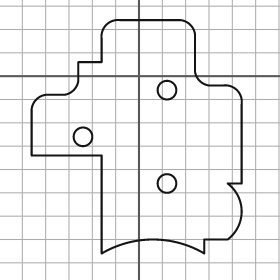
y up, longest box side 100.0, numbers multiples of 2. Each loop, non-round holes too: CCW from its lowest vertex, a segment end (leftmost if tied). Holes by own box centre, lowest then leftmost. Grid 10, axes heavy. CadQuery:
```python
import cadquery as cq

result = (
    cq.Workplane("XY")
    .moveTo(-16.0, -76.0)
    .threePointArc((6.0, -70.0), (28.0, -76.0))
    .lineTo(28.0, -70.0)
    .lineTo(38.0, -70.0)
    .threePointArc((44.0, -58.0), (38.0, -46.0))
    .lineTo(44.0, -46.0)
    .lineTo(44.0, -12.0)
    .threePointArc((42.0, -6.0), (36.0, -4.0))
    .lineTo(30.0, -4.0)
    .threePointArc((26.0, -2.0), (24.0, 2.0))
    .lineTo(24.0, 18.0)
    .threePointArc((22.0, 22.0), (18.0, 24.0))
    .lineTo(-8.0, 24.0)
    .threePointArc((-14.0, 22.0), (-16.0, 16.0))
    .lineTo(-16.0, 6.0)
    .lineTo(-26.0, 6.0)
    .lineTo(-26.0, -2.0)
    .threePointArc((-28.0, -6.0), (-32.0, -8.0))
    .lineTo(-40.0, -8.0)
    .threePointArc((-44.0, -10.0), (-46.0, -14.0))
    .lineTo(-46.0, -34.0)
    .lineTo(-16.0, -34.0)
    .close()
    .moveTo(12.0, -46.0)
    .circle(4.0)
    .moveTo(-24.0, -26.0)
    .circle(4.0)
    .moveTo(12.0, -6.0)
    .circle(4.0)
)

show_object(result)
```